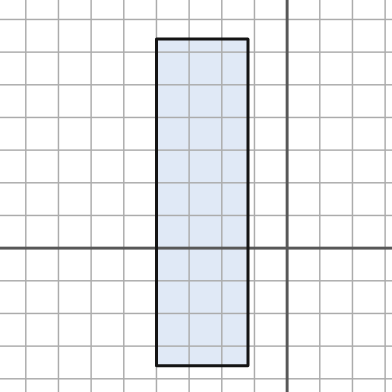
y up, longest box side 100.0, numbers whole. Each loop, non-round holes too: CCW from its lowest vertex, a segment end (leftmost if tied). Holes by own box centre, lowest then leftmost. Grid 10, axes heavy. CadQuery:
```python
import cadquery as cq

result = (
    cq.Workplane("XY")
    .moveTo(-40.0, -36.0)
    .lineTo(-12.0, -36.0)
    .lineTo(-12.0, 64.0)
    .lineTo(-40.0, 64.0)
    .close()
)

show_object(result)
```